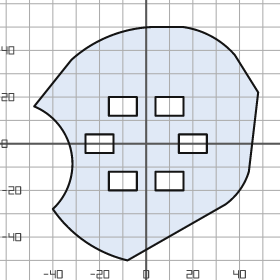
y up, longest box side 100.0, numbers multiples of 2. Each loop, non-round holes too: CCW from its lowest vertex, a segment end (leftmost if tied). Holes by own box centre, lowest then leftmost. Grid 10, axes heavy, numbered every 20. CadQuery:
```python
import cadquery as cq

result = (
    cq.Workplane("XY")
    .moveTo(-8.0, -50.0)
    .lineTo(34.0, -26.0)
    .threePointArc((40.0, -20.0), (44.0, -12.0))
    .lineTo(48.0, 22.0)
    .lineTo(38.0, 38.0)
    .threePointArc((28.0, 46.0), (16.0, 50.0))
    .lineTo(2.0, 50.0)
    .threePointArc((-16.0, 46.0), (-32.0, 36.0))
    .lineTo(-48.0, 16.0)
    .threePointArc((-32.0, -4.0), (-40.0, -28.0))
    .threePointArc((-26.0, -42.0), (-8.0, -50.0))
    .close()
    .moveTo(-16.0, -20.0)
    .lineTo(-4.0, -20.0)
    .lineTo(-4.0, -12.0)
    .lineTo(-16.0, -12.0)
    .close()
    .moveTo(4.0, -20.0)
    .lineTo(16.0, -20.0)
    .lineTo(16.0, -12.0)
    .lineTo(4.0, -12.0)
    .close()
    .moveTo(-26.0, -4.0)
    .lineTo(-14.0, -4.0)
    .lineTo(-14.0, 4.0)
    .lineTo(-26.0, 4.0)
    .close()
    .moveTo(14.0, -4.0)
    .lineTo(26.0, -4.0)
    .lineTo(26.0, 4.0)
    .lineTo(14.0, 4.0)
    .close()
    .moveTo(-16.0, 12.0)
    .lineTo(-4.0, 12.0)
    .lineTo(-4.0, 20.0)
    .lineTo(-16.0, 20.0)
    .close()
    .moveTo(4.0, 12.0)
    .lineTo(16.0, 12.0)
    .lineTo(16.0, 20.0)
    .lineTo(4.0, 20.0)
    .close()
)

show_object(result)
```